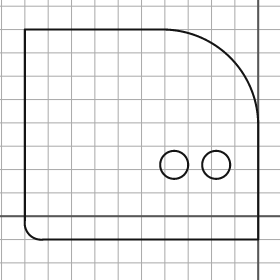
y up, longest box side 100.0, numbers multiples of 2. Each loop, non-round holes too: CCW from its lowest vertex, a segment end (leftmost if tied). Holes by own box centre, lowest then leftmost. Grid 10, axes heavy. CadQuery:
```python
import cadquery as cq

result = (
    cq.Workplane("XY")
    .moveTo(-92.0, -10.0)
    .lineTo(0.0, -10.0)
    .lineTo(0.0, 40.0)
    .threePointArc((-12.0, 68.0), (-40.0, 80.0))
    .lineTo(-100.0, 80.0)
    .lineTo(-100.0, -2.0)
    .threePointArc((-98.0, -8.0), (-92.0, -10.0))
    .close()
    .moveTo(-36.0, 22.0)
    .circle(6.0)
    .moveTo(-18.0, 22.0)
    .circle(6.0)
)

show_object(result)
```